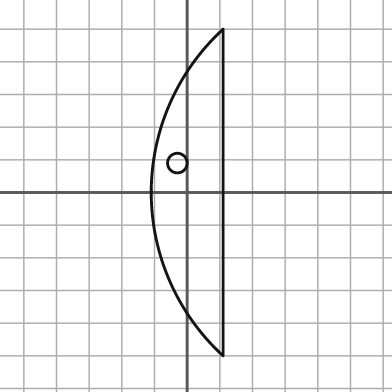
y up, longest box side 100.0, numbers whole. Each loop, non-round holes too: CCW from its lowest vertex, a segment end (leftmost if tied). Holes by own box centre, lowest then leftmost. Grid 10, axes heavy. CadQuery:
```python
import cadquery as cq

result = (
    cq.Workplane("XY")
    .moveTo(11.0, -50.0)
    .lineTo(11.0, 50.0)
    .threePointArc((-11.0, 0.0), (11.0, -50.0))
    .close()
    .moveTo(-3.0, 9.0)
    .circle(3.0)
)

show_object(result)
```